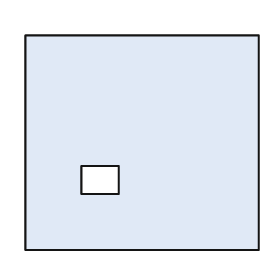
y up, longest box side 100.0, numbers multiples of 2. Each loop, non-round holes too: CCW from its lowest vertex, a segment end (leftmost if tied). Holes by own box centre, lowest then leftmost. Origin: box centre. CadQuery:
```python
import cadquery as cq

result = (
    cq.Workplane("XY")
    .moveTo(-50.0, -46.0)
    .lineTo(50.0, -46.0)
    .lineTo(50.0, 46.0)
    .lineTo(-50.0, 46.0)
    .close()
    .moveTo(-26.0, -22.0)
    .lineTo(-10.0, -22.0)
    .lineTo(-10.0, -10.0)
    .lineTo(-26.0, -10.0)
    .close()
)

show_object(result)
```